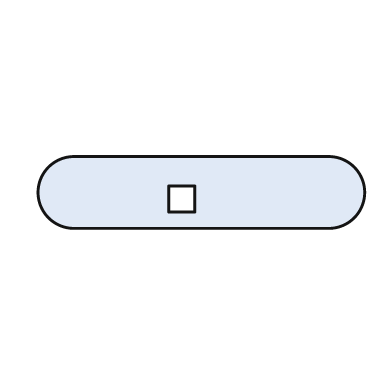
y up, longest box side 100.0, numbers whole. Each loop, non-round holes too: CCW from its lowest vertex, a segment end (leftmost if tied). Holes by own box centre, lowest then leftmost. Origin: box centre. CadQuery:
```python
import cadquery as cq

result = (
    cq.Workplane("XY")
    .moveTo(-39.0, -11.0)
    .lineTo(39.0, -11.0)
    .threePointArc((50.0, 0.0), (39.0, 11.0))
    .lineTo(-39.0, 11.0)
    .threePointArc((-50.0, 0.0), (-39.0, -11.0))
    .close()
    .moveTo(-10.0, -6.0)
    .lineTo(-2.0, -6.0)
    .lineTo(-2.0, 2.0)
    .lineTo(-10.0, 2.0)
    .close()
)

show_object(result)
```